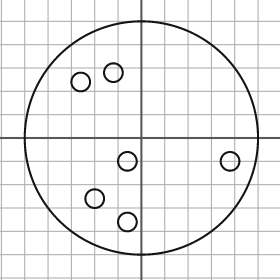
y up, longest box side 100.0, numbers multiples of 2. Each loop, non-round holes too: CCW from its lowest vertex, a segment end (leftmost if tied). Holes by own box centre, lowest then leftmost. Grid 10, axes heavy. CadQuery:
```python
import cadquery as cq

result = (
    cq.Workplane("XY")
    .moveTo(0.0, 0.0)
    .circle(50.0)
    .moveTo(-6.0, -36.0)
    .circle(4.0)
    .moveTo(-20.0, -26.0)
    .circle(4.0)
    .moveTo(-6.0, -10.0)
    .circle(4.0)
    .moveTo(38.0, -10.0)
    .circle(4.0)
    .moveTo(-26.0, 24.0)
    .circle(4.0)
    .moveTo(-12.0, 28.0)
    .circle(4.0)
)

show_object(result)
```